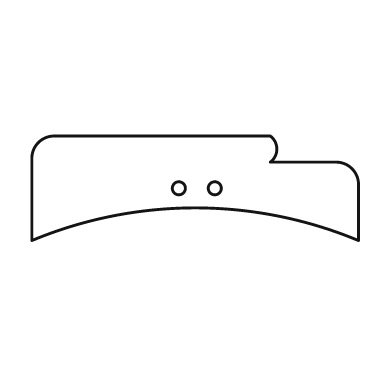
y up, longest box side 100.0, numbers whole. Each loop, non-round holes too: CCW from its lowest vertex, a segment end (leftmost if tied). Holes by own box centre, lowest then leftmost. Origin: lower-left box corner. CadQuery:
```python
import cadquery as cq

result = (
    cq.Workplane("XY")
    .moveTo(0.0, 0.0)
    .threePointArc((50.0, 10.0), (100.0, 0.0))
    .lineTo(100.0, 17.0)
    .threePointArc((98.0, 22.0), (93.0, 24.0))
    .lineTo(73.0, 24.0)
    .threePointArc((75.0, 28.0), (73.0, 32.0))
    .lineTo(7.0, 32.0)
    .threePointArc((2.0, 30.0), (0.0, 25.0))
    .close()
    .moveTo(45.0, 16.0)
    .circle(2.0)
    .moveTo(56.0, 16.0)
    .circle(2.0)
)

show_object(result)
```